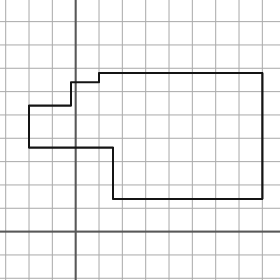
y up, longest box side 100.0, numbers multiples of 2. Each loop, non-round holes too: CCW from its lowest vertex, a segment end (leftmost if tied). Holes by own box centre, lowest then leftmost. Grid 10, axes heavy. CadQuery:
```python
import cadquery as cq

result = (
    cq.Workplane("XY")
    .moveTo(16.0, 14.0)
    .lineTo(80.0, 14.0)
    .lineTo(80.0, 68.0)
    .lineTo(10.0, 68.0)
    .lineTo(10.0, 64.0)
    .lineTo(-2.0, 64.0)
    .lineTo(-2.0, 54.0)
    .lineTo(-20.0, 54.0)
    .lineTo(-20.0, 36.0)
    .lineTo(16.0, 36.0)
    .close()
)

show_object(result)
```